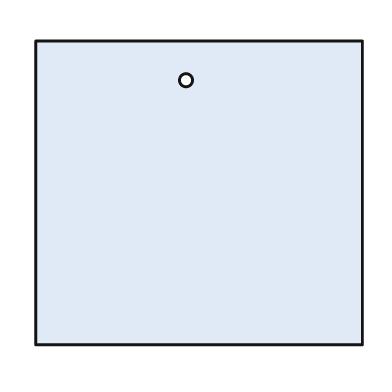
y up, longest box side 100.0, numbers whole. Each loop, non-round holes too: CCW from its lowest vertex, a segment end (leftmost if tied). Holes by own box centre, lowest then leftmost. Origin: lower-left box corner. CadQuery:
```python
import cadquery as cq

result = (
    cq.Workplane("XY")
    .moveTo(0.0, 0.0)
    .lineTo(100.0, 0.0)
    .lineTo(100.0, 93.0)
    .lineTo(0.0, 93.0)
    .close()
    .moveTo(46.0, 81.0)
    .circle(2.0)
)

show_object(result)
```